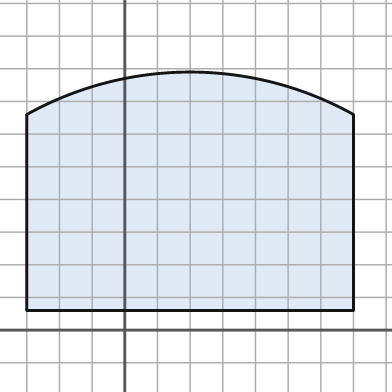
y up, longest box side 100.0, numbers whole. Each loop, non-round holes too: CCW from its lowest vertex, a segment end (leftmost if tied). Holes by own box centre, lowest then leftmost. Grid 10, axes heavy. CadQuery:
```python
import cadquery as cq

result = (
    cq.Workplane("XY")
    .moveTo(-30.0, 6.0)
    .lineTo(70.0, 6.0)
    .lineTo(70.0, 66.0)
    .threePointArc((20.0, 79.0), (-30.0, 66.0))
    .close()
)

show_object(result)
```